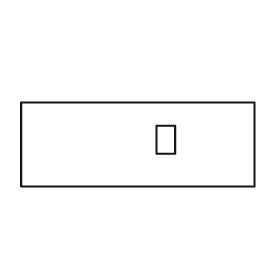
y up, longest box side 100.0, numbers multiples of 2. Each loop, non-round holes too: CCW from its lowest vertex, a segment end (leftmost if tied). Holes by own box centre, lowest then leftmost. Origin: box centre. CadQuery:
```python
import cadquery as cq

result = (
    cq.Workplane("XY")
    .moveTo(-50.0, -18.0)
    .lineTo(50.0, -18.0)
    .lineTo(50.0, 18.0)
    .lineTo(-50.0, 18.0)
    .close()
    .moveTo(8.0, -4.0)
    .lineTo(16.0, -4.0)
    .lineTo(16.0, 8.0)
    .lineTo(8.0, 8.0)
    .close()
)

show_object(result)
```